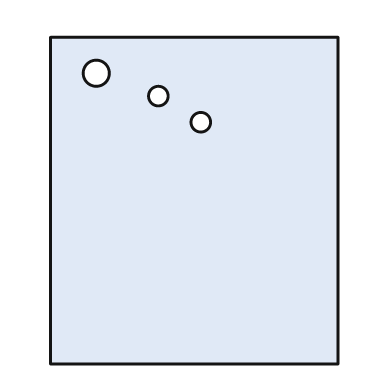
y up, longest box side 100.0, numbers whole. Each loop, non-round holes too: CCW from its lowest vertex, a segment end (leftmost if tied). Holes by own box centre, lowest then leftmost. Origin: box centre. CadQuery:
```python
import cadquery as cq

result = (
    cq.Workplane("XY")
    .moveTo(-44.0, -50.0)
    .lineTo(44.0, -50.0)
    .lineTo(44.0, 50.0)
    .lineTo(-44.0, 50.0)
    .close()
    .moveTo(2.0, 24.0)
    .circle(3.0)
    .moveTo(-11.0, 32.0)
    .circle(3.0)
    .moveTo(-30.0, 39.0)
    .circle(4.0)
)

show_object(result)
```